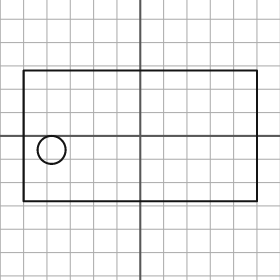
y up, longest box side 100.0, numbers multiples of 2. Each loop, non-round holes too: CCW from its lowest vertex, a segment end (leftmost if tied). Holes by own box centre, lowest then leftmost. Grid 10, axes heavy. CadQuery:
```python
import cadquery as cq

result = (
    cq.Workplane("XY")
    .moveTo(-50.0, -28.0)
    .lineTo(50.0, -28.0)
    .lineTo(50.0, 28.0)
    .lineTo(-50.0, 28.0)
    .close()
    .moveTo(-38.0, -6.0)
    .circle(6.0)
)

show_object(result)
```